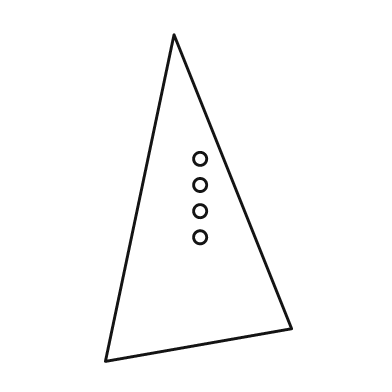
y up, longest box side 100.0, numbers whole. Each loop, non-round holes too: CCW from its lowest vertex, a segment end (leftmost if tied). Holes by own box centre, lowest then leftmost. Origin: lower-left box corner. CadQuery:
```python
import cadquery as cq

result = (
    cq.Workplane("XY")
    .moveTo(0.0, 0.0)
    .lineTo(57.0, 10.0)
    .lineTo(21.0, 100.0)
    .close()
    .moveTo(29.0, 38.0)
    .circle(2.0)
    .moveTo(29.0, 46.0)
    .circle(2.0)
    .moveTo(29.0, 54.0)
    .circle(2.0)
    .moveTo(29.0, 62.0)
    .circle(2.0)
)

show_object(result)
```